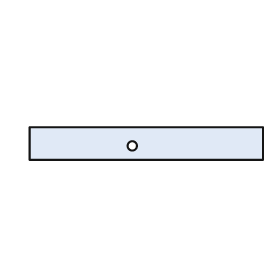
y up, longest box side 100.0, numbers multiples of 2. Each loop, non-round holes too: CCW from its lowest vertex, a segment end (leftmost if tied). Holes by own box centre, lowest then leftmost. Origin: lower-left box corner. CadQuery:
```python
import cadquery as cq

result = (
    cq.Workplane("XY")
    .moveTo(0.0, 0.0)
    .lineTo(100.0, 0.0)
    .lineTo(100.0, 14.0)
    .lineTo(0.0, 14.0)
    .close()
    .moveTo(44.0, 6.0)
    .circle(2.0)
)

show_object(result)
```